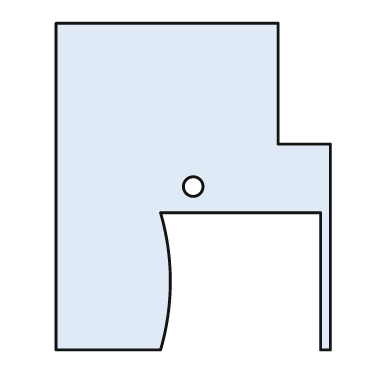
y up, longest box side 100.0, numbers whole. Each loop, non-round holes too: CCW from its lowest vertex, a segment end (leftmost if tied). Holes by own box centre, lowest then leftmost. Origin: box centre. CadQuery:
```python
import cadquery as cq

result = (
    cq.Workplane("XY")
    .moveTo(-42.0, -50.0)
    .lineTo(-10.0, -50.0)
    .threePointArc((-7.0, -29.0), (-10.0, -8.0))
    .lineTo(39.0, -8.0)
    .lineTo(39.0, -50.0)
    .lineTo(42.0, -50.0)
    .lineTo(42.0, 13.0)
    .lineTo(26.0, 13.0)
    .lineTo(26.0, 50.0)
    .lineTo(-42.0, 50.0)
    .close()
    .moveTo(0.0, 0.0)
    .circle(3.0)
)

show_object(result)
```